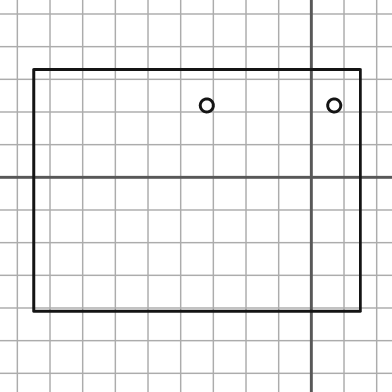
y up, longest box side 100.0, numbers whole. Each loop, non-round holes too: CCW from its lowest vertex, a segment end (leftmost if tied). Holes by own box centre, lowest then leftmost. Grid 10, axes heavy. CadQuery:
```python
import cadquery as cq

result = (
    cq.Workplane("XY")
    .moveTo(-85.0, -41.0)
    .lineTo(15.0, -41.0)
    .lineTo(15.0, 33.0)
    .lineTo(-85.0, 33.0)
    .close()
    .moveTo(-32.0, 22.0)
    .circle(2.0)
    .moveTo(7.0, 22.0)
    .circle(2.0)
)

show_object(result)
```